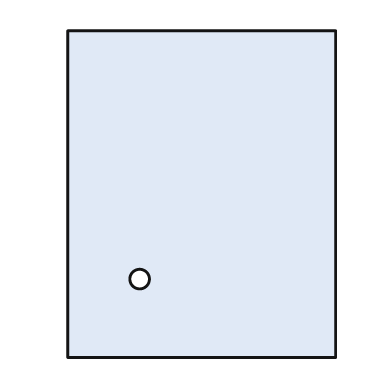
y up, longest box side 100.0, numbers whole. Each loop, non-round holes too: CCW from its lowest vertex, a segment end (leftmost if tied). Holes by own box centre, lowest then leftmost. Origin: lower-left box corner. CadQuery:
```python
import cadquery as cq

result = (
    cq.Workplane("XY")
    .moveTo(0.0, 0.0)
    .lineTo(82.0, 0.0)
    .lineTo(82.0, 100.0)
    .lineTo(0.0, 100.0)
    .close()
    .moveTo(22.0, 24.0)
    .circle(3.0)
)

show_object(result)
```